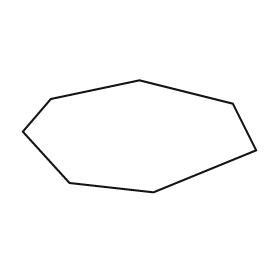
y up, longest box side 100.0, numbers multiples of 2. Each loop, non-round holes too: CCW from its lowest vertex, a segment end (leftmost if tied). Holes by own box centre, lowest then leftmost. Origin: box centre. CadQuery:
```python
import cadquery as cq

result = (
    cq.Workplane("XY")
    .moveTo(6.0, -24.0)
    .lineTo(50.0, -6.0)
    .lineTo(40.0, 14.0)
    .lineTo(0.0, 24.0)
    .lineTo(-38.0, 16.0)
    .lineTo(-50.0, 2.0)
    .lineTo(-30.0, -20.0)
    .close()
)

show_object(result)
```